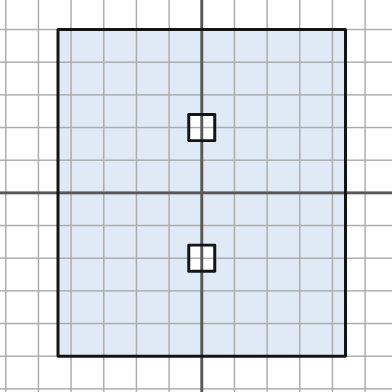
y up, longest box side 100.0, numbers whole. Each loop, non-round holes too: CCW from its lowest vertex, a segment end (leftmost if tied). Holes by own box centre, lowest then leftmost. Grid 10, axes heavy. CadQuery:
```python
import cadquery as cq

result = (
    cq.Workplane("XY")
    .moveTo(-44.0, -50.0)
    .lineTo(44.0, -50.0)
    .lineTo(44.0, 50.0)
    .lineTo(-44.0, 50.0)
    .close()
    .moveTo(-4.0, -24.0)
    .lineTo(4.0, -24.0)
    .lineTo(4.0, -16.0)
    .lineTo(-4.0, -16.0)
    .close()
    .moveTo(-4.0, 16.0)
    .lineTo(4.0, 16.0)
    .lineTo(4.0, 24.0)
    .lineTo(-4.0, 24.0)
    .close()
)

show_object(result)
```